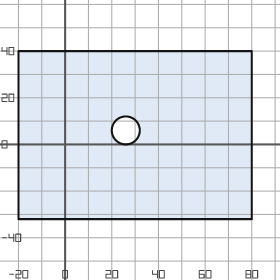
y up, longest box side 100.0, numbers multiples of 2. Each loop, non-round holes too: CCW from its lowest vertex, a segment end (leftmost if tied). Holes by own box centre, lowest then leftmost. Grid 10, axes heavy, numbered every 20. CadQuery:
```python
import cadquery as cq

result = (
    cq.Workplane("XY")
    .moveTo(-20.0, -32.0)
    .lineTo(80.0, -32.0)
    .lineTo(80.0, 40.0)
    .lineTo(-20.0, 40.0)
    .close()
    .moveTo(26.0, 6.0)
    .circle(6.0)
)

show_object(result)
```